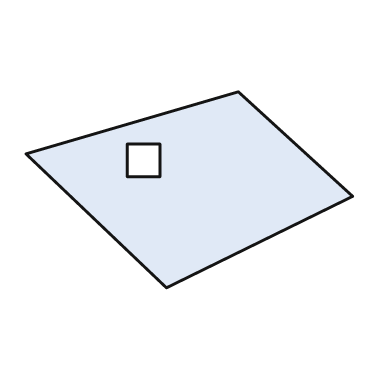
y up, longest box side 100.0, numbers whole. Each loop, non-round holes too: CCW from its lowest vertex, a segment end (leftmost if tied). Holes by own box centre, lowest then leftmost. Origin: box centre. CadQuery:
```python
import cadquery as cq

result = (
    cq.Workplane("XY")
    .moveTo(-7.0, -30.0)
    .lineTo(50.0, -2.0)
    .lineTo(15.0, 30.0)
    .lineTo(-50.0, 11.0)
    .close()
    .moveTo(-19.0, 4.0)
    .lineTo(-9.0, 4.0)
    .lineTo(-9.0, 14.0)
    .lineTo(-19.0, 14.0)
    .close()
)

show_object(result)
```